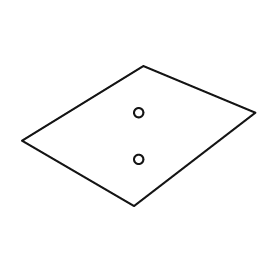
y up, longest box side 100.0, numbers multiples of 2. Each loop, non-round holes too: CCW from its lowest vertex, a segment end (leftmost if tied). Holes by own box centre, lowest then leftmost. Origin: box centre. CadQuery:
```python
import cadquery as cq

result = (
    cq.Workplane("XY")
    .moveTo(-2.0, -30.0)
    .lineTo(50.0, 10.0)
    .lineTo(2.0, 30.0)
    .lineTo(-50.0, -2.0)
    .close()
    .moveTo(0.0, -10.0)
    .circle(2.0)
    .moveTo(0.0, 10.0)
    .circle(2.0)
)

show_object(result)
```